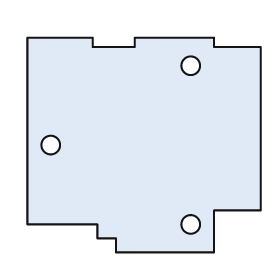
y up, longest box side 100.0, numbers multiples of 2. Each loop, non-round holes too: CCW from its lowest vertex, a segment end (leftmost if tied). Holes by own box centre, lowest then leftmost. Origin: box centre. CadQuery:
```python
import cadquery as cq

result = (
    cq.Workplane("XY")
    .moveTo(-12.0, -46.0)
    .lineTo(30.0, -46.0)
    .lineTo(30.0, -28.0)
    .lineTo(50.0, -28.0)
    .lineTo(50.0, 42.0)
    .lineTo(30.0, 42.0)
    .lineTo(30.0, 46.0)
    .lineTo(-4.0, 46.0)
    .lineTo(-4.0, 42.0)
    .lineTo(-22.0, 42.0)
    .lineTo(-22.0, 46.0)
    .lineTo(-50.0, 46.0)
    .lineTo(-50.0, -34.0)
    .lineTo(-20.0, -34.0)
    .lineTo(-20.0, -40.0)
    .lineTo(-12.0, -40.0)
    .close()
    .moveTo(20.0, -34.0)
    .circle(4.0)
    .moveTo(-40.0, 0.0)
    .circle(4.0)
    .moveTo(20.0, 34.0)
    .circle(4.0)
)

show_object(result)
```